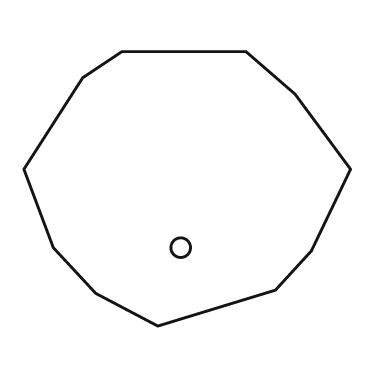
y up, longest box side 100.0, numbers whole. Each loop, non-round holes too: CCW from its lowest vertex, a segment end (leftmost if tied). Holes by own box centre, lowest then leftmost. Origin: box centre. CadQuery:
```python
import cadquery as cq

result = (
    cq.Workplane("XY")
    .moveTo(-9.0, -42.0)
    .lineTo(27.0, -31.0)
    .lineTo(38.0, -19.0)
    .lineTo(50.0, 6.0)
    .lineTo(33.0, 29.0)
    .lineTo(18.0, 42.0)
    .lineTo(-20.0, 42.0)
    .lineTo(-32.0, 34.0)
    .lineTo(-50.0, 6.0)
    .lineTo(-41.0, -18.0)
    .lineTo(-28.0, -32.0)
    .close()
    .moveTo(-2.0, -18.0)
    .circle(3.0)
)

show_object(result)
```